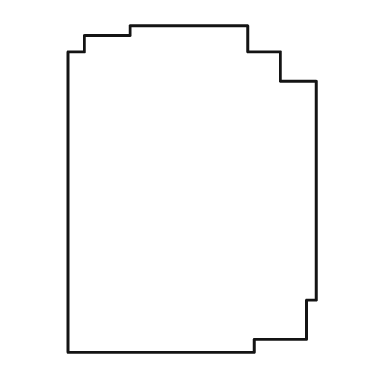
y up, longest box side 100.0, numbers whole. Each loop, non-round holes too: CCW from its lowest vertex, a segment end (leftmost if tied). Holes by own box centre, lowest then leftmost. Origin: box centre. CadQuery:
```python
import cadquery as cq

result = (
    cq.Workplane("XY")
    .moveTo(-38.0, -50.0)
    .lineTo(19.0, -50.0)
    .lineTo(19.0, -46.0)
    .lineTo(35.0, -46.0)
    .lineTo(35.0, -34.0)
    .lineTo(38.0, -34.0)
    .lineTo(38.0, 33.0)
    .lineTo(27.0, 33.0)
    .lineTo(27.0, 42.0)
    .lineTo(17.0, 42.0)
    .lineTo(17.0, 50.0)
    .lineTo(-19.0, 50.0)
    .lineTo(-19.0, 47.0)
    .lineTo(-33.0, 47.0)
    .lineTo(-33.0, 42.0)
    .lineTo(-38.0, 42.0)
    .close()
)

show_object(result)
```